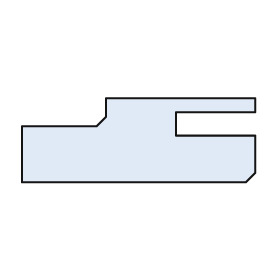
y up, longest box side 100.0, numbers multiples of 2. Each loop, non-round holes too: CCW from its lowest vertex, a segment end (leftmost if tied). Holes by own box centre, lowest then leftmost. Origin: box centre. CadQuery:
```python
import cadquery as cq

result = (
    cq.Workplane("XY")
    .moveTo(-50.0, -18.0)
    .lineTo(46.0, -18.0)
    .lineTo(50.0, -14.0)
    .lineTo(50.0, 2.0)
    .lineTo(16.0, 2.0)
    .lineTo(16.0, 12.0)
    .lineTo(50.0, 12.0)
    .lineTo(50.0, 18.0)
    .lineTo(-14.0, 18.0)
    .lineTo(-14.0, 10.0)
    .lineTo(-18.0, 6.0)
    .lineTo(-50.0, 6.0)
    .close()
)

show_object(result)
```